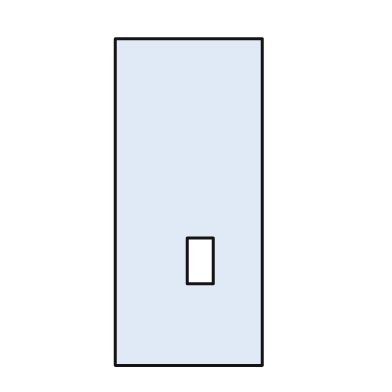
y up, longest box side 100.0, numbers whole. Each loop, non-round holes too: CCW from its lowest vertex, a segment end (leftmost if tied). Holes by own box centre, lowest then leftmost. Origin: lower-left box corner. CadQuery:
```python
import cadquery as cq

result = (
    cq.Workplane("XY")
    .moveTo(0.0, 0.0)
    .lineTo(45.0, 0.0)
    .lineTo(45.0, 100.0)
    .lineTo(0.0, 100.0)
    .close()
    .moveTo(22.0, 25.0)
    .lineTo(30.0, 25.0)
    .lineTo(30.0, 39.0)
    .lineTo(22.0, 39.0)
    .close()
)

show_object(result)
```